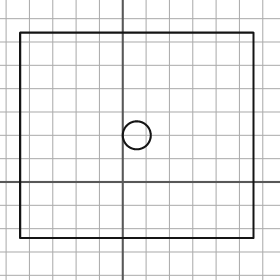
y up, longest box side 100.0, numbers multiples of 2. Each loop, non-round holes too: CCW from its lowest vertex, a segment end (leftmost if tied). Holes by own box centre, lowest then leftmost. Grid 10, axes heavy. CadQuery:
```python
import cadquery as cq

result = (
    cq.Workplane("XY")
    .moveTo(-44.0, -24.0)
    .lineTo(56.0, -24.0)
    .lineTo(56.0, 64.0)
    .lineTo(-44.0, 64.0)
    .close()
    .moveTo(6.0, 20.0)
    .circle(6.0)
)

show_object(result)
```